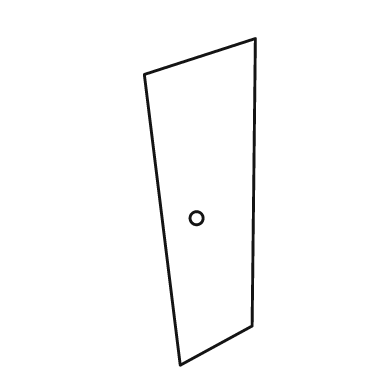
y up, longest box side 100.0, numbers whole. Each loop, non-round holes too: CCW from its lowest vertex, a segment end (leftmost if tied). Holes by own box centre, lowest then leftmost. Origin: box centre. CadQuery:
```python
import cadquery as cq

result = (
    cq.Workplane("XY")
    .moveTo(-6.0, -50.0)
    .lineTo(16.0, -38.0)
    .lineTo(17.0, 50.0)
    .lineTo(-17.0, 39.0)
    .close()
    .moveTo(-1.0, -5.0)
    .circle(2.0)
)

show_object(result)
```